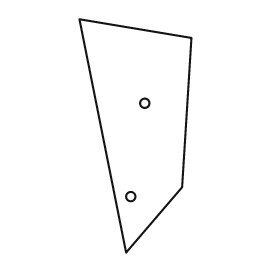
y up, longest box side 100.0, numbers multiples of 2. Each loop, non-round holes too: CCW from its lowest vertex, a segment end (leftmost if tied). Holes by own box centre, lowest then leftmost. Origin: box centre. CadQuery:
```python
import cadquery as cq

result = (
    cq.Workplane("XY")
    .moveTo(-4.0, -50.0)
    .lineTo(20.0, -22.0)
    .lineTo(24.0, 42.0)
    .lineTo(-24.0, 50.0)
    .close()
    .moveTo(-2.0, -26.0)
    .circle(2.0)
    .moveTo(4.0, 14.0)
    .circle(2.0)
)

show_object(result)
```